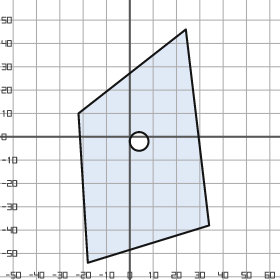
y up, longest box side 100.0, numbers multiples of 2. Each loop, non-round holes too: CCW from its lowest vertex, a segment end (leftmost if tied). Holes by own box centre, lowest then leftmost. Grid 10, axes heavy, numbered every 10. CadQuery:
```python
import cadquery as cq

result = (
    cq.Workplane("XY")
    .moveTo(-18.0, -54.0)
    .lineTo(34.0, -38.0)
    .lineTo(24.0, 46.0)
    .lineTo(-22.0, 10.0)
    .close()
    .moveTo(4.0, -2.0)
    .circle(4.0)
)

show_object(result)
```